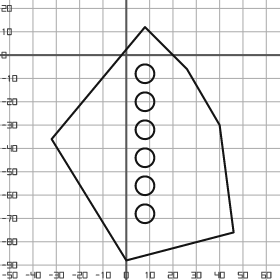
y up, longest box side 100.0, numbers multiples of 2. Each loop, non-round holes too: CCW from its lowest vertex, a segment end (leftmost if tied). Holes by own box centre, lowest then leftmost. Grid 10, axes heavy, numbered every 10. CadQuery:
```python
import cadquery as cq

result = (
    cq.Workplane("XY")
    .moveTo(0.0, -88.0)
    .lineTo(46.0, -76.0)
    .lineTo(40.0, -30.0)
    .lineTo(26.0, -6.0)
    .lineTo(8.0, 12.0)
    .lineTo(-32.0, -36.0)
    .close()
    .moveTo(8.0, -68.0)
    .circle(4.0)
    .moveTo(8.0, -56.0)
    .circle(4.0)
    .moveTo(8.0, -44.0)
    .circle(4.0)
    .moveTo(8.0, -32.0)
    .circle(4.0)
    .moveTo(8.0, -20.0)
    .circle(4.0)
    .moveTo(8.0, -8.0)
    .circle(4.0)
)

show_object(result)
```